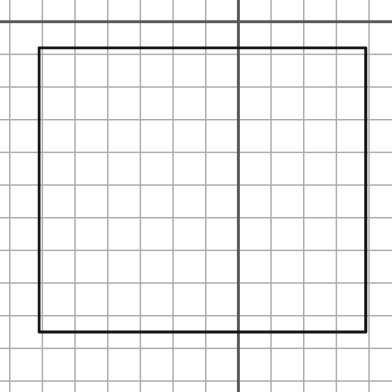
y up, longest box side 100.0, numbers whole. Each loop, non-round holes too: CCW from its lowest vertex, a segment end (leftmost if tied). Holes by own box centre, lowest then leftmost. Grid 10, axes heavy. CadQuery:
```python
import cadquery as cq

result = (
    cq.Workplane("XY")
    .moveTo(-61.0, -95.0)
    .lineTo(39.0, -95.0)
    .lineTo(39.0, -8.0)
    .lineTo(-61.0, -8.0)
    .close()
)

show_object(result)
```